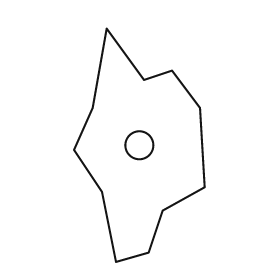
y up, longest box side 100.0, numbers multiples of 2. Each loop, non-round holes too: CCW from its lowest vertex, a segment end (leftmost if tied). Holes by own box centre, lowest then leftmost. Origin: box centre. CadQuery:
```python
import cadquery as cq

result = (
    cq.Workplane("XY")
    .moveTo(-10.0, -50.0)
    .lineTo(4.0, -46.0)
    .lineTo(10.0, -28.0)
    .lineTo(28.0, -18.0)
    .lineTo(26.0, 16.0)
    .lineTo(14.0, 32.0)
    .lineTo(2.0, 28.0)
    .lineTo(-14.0, 50.0)
    .lineTo(-20.0, 16.0)
    .lineTo(-28.0, -2.0)
    .lineTo(-16.0, -20.0)
    .close()
    .moveTo(0.0, 0.0)
    .circle(6.0)
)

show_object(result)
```